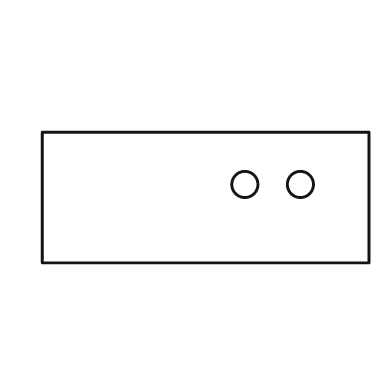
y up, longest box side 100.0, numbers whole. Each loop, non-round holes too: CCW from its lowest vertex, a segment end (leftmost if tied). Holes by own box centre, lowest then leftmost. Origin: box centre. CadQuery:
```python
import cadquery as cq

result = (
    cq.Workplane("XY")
    .moveTo(-50.0, -20.0)
    .lineTo(50.0, -20.0)
    .lineTo(50.0, 20.0)
    .lineTo(-50.0, 20.0)
    .close()
    .moveTo(12.0, 4.0)
    .circle(4.0)
    .moveTo(29.0, 4.0)
    .circle(4.0)
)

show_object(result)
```